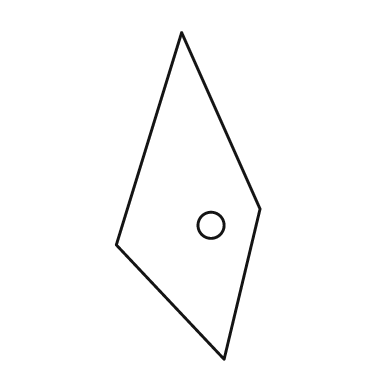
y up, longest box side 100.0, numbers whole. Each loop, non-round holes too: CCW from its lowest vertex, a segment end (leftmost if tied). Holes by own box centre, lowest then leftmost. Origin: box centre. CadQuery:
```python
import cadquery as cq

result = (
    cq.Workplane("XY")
    .moveTo(11.0, -50.0)
    .lineTo(22.0, -4.0)
    .lineTo(-2.0, 50.0)
    .lineTo(-22.0, -15.0)
    .close()
    .moveTo(7.0, -9.0)
    .circle(4.0)
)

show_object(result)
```